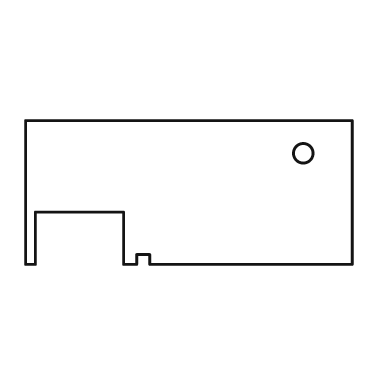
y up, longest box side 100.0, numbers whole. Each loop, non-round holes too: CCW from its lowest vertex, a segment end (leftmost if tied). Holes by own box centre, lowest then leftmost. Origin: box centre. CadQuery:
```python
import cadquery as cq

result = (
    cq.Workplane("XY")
    .moveTo(-50.0, -22.0)
    .lineTo(-47.0, -22.0)
    .lineTo(-47.0, -6.0)
    .lineTo(-20.0, -6.0)
    .lineTo(-20.0, -22.0)
    .lineTo(-16.0, -22.0)
    .lineTo(-16.0, -19.0)
    .lineTo(-12.0, -19.0)
    .lineTo(-12.0, -22.0)
    .lineTo(50.0, -22.0)
    .lineTo(50.0, 22.0)
    .lineTo(-50.0, 22.0)
    .close()
    .moveTo(35.0, 12.0)
    .circle(3.0)
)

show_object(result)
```